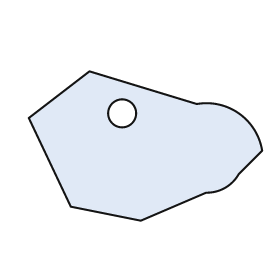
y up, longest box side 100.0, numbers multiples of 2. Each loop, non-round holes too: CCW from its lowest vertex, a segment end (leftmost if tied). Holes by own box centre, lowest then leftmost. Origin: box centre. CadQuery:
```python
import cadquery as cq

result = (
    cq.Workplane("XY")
    .moveTo(-2.0, -32.0)
    .lineTo(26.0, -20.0)
    .threePointArc((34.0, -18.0), (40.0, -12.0))
    .lineTo(50.0, -2.0)
    .threePointArc((40.0, 14.0), (22.0, 18.0))
    .lineTo(-24.0, 32.0)
    .lineTo(-50.0, 12.0)
    .lineTo(-32.0, -26.0)
    .close()
    .moveTo(-10.0, 14.0)
    .circle(6.0)
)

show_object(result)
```